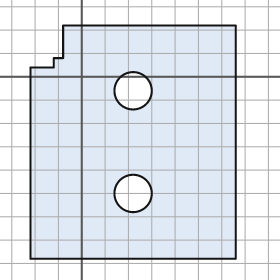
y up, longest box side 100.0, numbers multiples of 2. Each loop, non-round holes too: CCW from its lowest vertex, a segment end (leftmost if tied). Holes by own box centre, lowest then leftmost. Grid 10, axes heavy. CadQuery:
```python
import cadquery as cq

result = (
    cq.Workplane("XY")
    .moveTo(-22.0, -78.0)
    .lineTo(66.0, -78.0)
    .lineTo(66.0, 22.0)
    .lineTo(-8.0, 22.0)
    .lineTo(-8.0, 8.0)
    .lineTo(-12.0, 8.0)
    .lineTo(-12.0, 4.0)
    .lineTo(-22.0, 4.0)
    .close()
    .moveTo(22.0, -50.0)
    .circle(8.0)
    .moveTo(22.0, -6.0)
    .circle(8.0)
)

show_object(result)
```